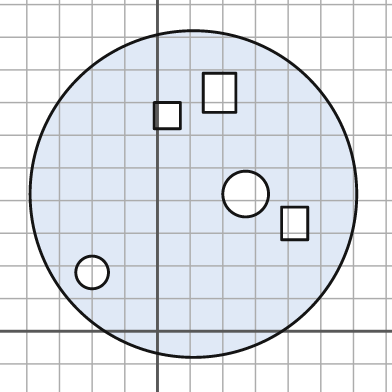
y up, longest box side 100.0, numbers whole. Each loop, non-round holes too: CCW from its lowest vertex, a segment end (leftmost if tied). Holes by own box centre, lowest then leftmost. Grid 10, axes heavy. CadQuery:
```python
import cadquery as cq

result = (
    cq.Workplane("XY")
    .moveTo(11.0, 42.0)
    .circle(50.0)
    .moveTo(-20.0, 18.0)
    .circle(5.0)
    .moveTo(38.0, 28.0)
    .lineTo(46.0, 28.0)
    .lineTo(46.0, 38.0)
    .lineTo(38.0, 38.0)
    .close()
    .moveTo(27.0, 42.0)
    .circle(7.0)
    .moveTo(-1.0, 62.0)
    .lineTo(7.0, 62.0)
    .lineTo(7.0, 70.0)
    .lineTo(-1.0, 70.0)
    .close()
    .moveTo(14.0, 67.0)
    .lineTo(24.0, 67.0)
    .lineTo(24.0, 79.0)
    .lineTo(14.0, 79.0)
    .close()
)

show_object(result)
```